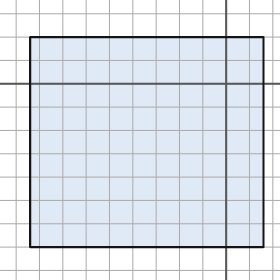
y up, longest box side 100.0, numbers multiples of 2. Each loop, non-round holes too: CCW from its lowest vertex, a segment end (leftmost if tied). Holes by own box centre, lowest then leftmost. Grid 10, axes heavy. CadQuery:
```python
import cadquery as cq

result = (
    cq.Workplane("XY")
    .moveTo(-84.0, -70.0)
    .lineTo(16.0, -70.0)
    .lineTo(16.0, 20.0)
    .lineTo(-84.0, 20.0)
    .close()
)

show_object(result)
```